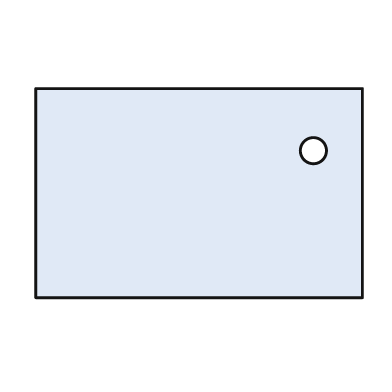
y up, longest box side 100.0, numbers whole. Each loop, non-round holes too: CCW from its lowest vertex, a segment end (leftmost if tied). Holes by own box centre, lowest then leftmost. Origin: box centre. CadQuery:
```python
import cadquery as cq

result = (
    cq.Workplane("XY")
    .moveTo(-50.0, -32.0)
    .lineTo(50.0, -32.0)
    .lineTo(50.0, 32.0)
    .lineTo(-50.0, 32.0)
    .close()
    .moveTo(35.0, 13.0)
    .circle(4.0)
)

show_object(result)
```